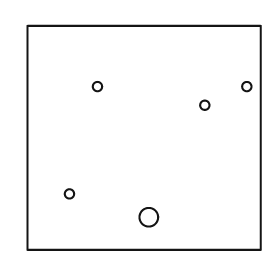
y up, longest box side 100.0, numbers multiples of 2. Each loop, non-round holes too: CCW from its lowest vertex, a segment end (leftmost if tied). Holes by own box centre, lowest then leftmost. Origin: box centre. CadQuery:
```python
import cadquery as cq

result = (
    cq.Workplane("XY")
    .moveTo(-50.0, -48.0)
    .lineTo(50.0, -48.0)
    .lineTo(50.0, 48.0)
    .lineTo(-50.0, 48.0)
    .close()
    .moveTo(2.0, -34.0)
    .circle(4.0)
    .moveTo(-32.0, -24.0)
    .circle(2.0)
    .moveTo(26.0, 14.0)
    .circle(2.0)
    .moveTo(-20.0, 22.0)
    .circle(2.0)
    .moveTo(44.0, 22.0)
    .circle(2.0)
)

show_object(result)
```